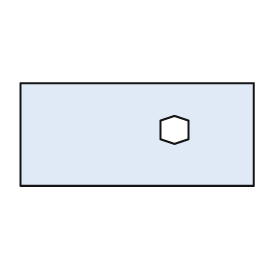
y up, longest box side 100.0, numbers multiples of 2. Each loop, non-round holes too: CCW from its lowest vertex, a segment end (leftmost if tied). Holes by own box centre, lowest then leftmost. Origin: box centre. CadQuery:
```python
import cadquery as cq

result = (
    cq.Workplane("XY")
    .moveTo(-50.0, -22.0)
    .lineTo(50.0, -22.0)
    .lineTo(50.0, 22.0)
    .lineTo(-50.0, 22.0)
    .close()
    .moveTo(16.0, -4.0)
    .lineTo(22.0, -2.0)
    .lineTo(22.0, 6.0)
    .lineTo(16.0, 8.0)
    .lineTo(10.0, 6.0)
    .lineTo(10.0, -2.0)
    .close()
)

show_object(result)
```